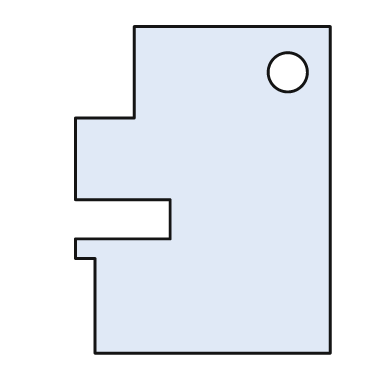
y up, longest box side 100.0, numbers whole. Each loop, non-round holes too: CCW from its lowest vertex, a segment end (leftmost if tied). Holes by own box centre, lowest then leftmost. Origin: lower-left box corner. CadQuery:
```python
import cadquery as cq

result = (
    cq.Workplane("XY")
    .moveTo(6.0, 0.0)
    .lineTo(78.0, 0.0)
    .lineTo(78.0, 100.0)
    .lineTo(18.0, 100.0)
    .lineTo(18.0, 72.0)
    .lineTo(0.0, 72.0)
    .lineTo(0.0, 47.0)
    .lineTo(29.0, 47.0)
    .lineTo(29.0, 35.0)
    .lineTo(0.0, 35.0)
    .lineTo(0.0, 29.0)
    .lineTo(6.0, 29.0)
    .close()
    .moveTo(65.0, 86.0)
    .circle(6.0)
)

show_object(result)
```